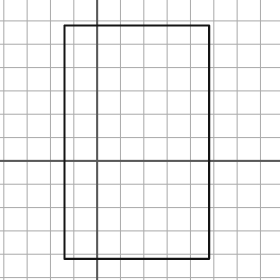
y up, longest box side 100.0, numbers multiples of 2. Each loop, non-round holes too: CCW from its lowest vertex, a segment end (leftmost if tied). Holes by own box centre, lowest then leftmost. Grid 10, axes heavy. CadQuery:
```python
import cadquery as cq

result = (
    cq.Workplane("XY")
    .moveTo(-14.0, -42.0)
    .lineTo(48.0, -42.0)
    .lineTo(48.0, 58.0)
    .lineTo(-14.0, 58.0)
    .close()
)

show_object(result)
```